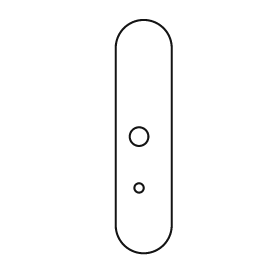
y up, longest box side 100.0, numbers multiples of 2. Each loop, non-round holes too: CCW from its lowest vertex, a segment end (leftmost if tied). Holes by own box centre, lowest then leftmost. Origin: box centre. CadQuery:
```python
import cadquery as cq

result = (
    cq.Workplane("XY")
    .moveTo(-12.0, -38.0)
    .threePointArc((0.0, -50.0), (12.0, -38.0))
    .lineTo(12.0, 38.0)
    .threePointArc((0.0, 50.0), (-12.0, 38.0))
    .close()
    .moveTo(-2.0, -22.0)
    .circle(2.0)
    .moveTo(-2.0, 0.0)
    .circle(4.0)
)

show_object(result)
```